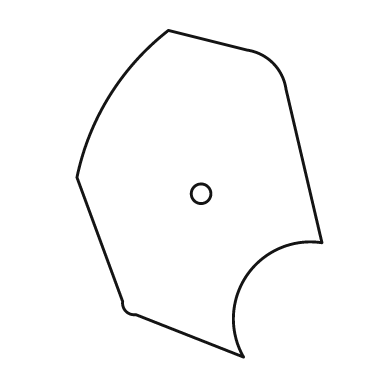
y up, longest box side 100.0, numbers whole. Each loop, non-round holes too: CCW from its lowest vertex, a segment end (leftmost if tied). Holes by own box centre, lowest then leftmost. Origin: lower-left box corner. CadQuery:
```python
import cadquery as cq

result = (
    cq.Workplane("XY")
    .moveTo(51.0, 0.0)
    .threePointArc((52.0, 25.0), (75.0, 35.0))
    .lineTo(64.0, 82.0)
    .threePointArc((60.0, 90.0), (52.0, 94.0))
    .lineTo(28.0, 100.0)
    .threePointArc((10.0, 80.0), (0.0, 55.0))
    .lineTo(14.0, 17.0)
    .threePointArc((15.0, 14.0), (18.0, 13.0))
    .close()
    .moveTo(38.0, 50.0)
    .circle(3.0)
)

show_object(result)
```